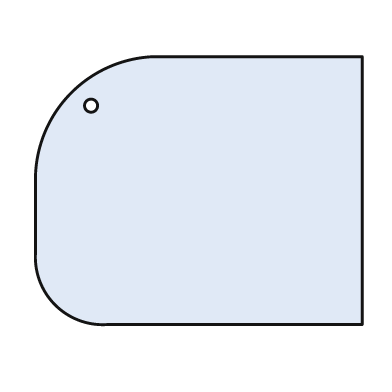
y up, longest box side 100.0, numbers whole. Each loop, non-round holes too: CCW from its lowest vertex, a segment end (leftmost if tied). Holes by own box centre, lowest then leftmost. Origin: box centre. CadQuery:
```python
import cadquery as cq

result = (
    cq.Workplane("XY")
    .moveTo(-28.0, -41.0)
    .lineTo(50.0, -41.0)
    .lineTo(50.0, 41.0)
    .lineTo(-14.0, 41.0)
    .threePointArc((-39.0, 30.0), (-50.0, 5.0))
    .lineTo(-50.0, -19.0)
    .threePointArc((-44.0, -35.0), (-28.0, -41.0))
    .close()
    .moveTo(-33.0, 26.0)
    .circle(2.0)
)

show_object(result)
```